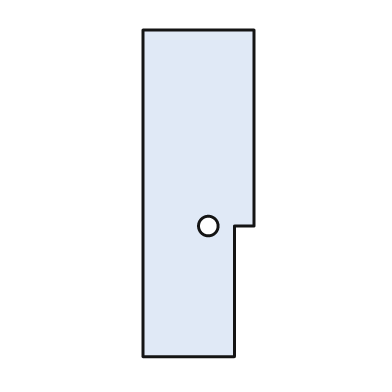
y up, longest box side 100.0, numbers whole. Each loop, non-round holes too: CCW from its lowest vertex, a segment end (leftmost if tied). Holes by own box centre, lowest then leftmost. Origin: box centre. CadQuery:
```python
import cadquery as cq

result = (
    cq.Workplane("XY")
    .moveTo(-17.0, -50.0)
    .lineTo(11.0, -50.0)
    .lineTo(11.0, -10.0)
    .lineTo(17.0, -10.0)
    .lineTo(17.0, 50.0)
    .lineTo(-17.0, 50.0)
    .close()
    .moveTo(3.0, -10.0)
    .circle(3.0)
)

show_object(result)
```